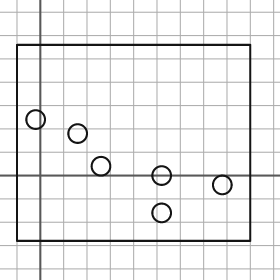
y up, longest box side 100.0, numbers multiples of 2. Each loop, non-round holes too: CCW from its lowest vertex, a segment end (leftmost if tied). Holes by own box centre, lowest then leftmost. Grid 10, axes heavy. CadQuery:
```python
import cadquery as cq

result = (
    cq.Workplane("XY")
    .moveTo(-10.0, -28.0)
    .lineTo(90.0, -28.0)
    .lineTo(90.0, 56.0)
    .lineTo(-10.0, 56.0)
    .close()
    .moveTo(52.0, -16.0)
    .circle(4.0)
    .moveTo(78.0, -4.0)
    .circle(4.0)
    .moveTo(52.0, 0.0)
    .circle(4.0)
    .moveTo(26.0, 4.0)
    .circle(4.0)
    .moveTo(16.0, 18.0)
    .circle(4.0)
    .moveTo(-2.0, 24.0)
    .circle(4.0)
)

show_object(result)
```